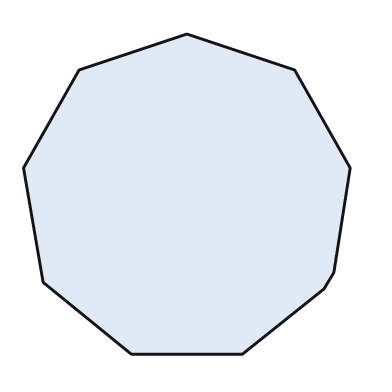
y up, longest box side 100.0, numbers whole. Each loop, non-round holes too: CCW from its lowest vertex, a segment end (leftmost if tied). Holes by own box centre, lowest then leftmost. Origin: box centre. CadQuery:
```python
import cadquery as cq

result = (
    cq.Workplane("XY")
    .moveTo(-17.0, -49.0)
    .lineTo(17.0, -49.0)
    .lineTo(42.0, -29.0)
    .lineTo(45.0, -24.0)
    .lineTo(50.0, 8.0)
    .lineTo(33.0, 38.0)
    .lineTo(0.0, 49.0)
    .lineTo(-33.0, 38.0)
    .lineTo(-50.0, 8.0)
    .lineTo(-44.0, -27.0)
    .close()
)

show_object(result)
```